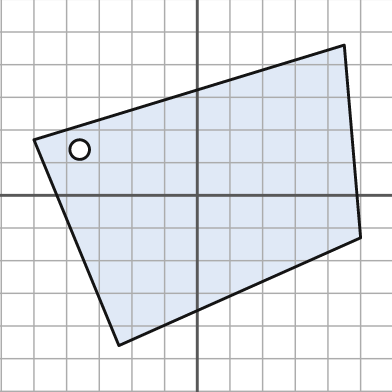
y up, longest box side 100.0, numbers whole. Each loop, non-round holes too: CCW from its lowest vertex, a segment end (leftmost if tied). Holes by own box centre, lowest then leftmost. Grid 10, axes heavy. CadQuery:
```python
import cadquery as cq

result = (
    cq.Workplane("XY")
    .moveTo(-24.0, -46.0)
    .lineTo(50.0, -13.0)
    .lineTo(45.0, 46.0)
    .lineTo(-50.0, 17.0)
    .close()
    .moveTo(-36.0, 14.0)
    .circle(3.0)
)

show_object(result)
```